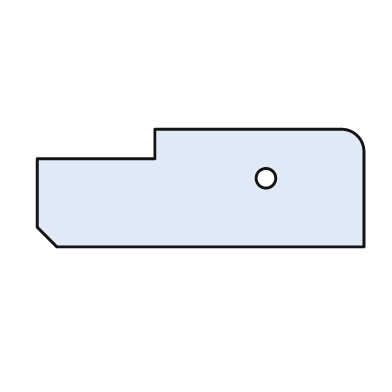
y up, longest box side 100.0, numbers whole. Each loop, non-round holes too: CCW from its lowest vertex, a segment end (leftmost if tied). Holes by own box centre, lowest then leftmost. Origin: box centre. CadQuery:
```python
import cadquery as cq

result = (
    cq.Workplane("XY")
    .moveTo(-44.0, -18.0)
    .lineTo(50.0, -18.0)
    .lineTo(50.0, 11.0)
    .threePointArc((48.0, 16.0), (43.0, 18.0))
    .lineTo(-14.0, 18.0)
    .lineTo(-14.0, 9.0)
    .lineTo(-50.0, 9.0)
    .lineTo(-50.0, -12.0)
    .close()
    .moveTo(20.0, 3.0)
    .circle(3.0)
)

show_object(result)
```